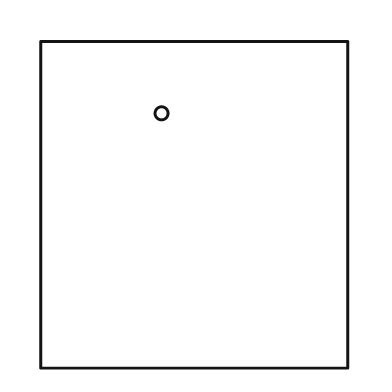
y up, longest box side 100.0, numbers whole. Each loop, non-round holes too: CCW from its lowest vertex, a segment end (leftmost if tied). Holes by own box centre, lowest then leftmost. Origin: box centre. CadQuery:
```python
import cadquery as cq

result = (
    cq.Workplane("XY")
    .moveTo(-47.0, -50.0)
    .lineTo(47.0, -50.0)
    .lineTo(47.0, 50.0)
    .lineTo(-47.0, 50.0)
    .close()
    .moveTo(-10.0, 28.0)
    .circle(2.0)
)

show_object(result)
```